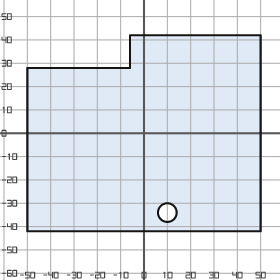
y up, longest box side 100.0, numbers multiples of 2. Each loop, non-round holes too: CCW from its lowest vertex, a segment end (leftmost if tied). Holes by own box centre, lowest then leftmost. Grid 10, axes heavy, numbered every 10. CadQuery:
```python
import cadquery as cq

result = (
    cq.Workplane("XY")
    .moveTo(-50.0, -42.0)
    .lineTo(50.0, -42.0)
    .lineTo(50.0, 42.0)
    .lineTo(-6.0, 42.0)
    .lineTo(-6.0, 28.0)
    .lineTo(-50.0, 28.0)
    .close()
    .moveTo(10.0, -34.0)
    .circle(4.0)
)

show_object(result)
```